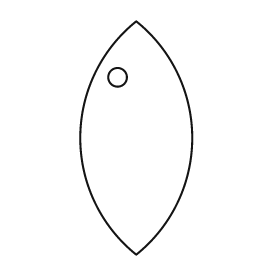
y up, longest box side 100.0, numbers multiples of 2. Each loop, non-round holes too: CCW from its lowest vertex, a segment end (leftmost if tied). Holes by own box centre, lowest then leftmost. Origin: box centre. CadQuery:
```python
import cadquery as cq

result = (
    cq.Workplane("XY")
    .moveTo(0.0, -50.0)
    .threePointArc((24.0, 0.0), (0.0, 50.0))
    .threePointArc((-24.0, 0.0), (0.0, -50.0))
    .close()
    .moveTo(-8.0, 26.0)
    .circle(4.0)
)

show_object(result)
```